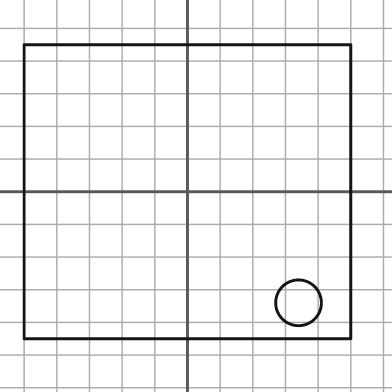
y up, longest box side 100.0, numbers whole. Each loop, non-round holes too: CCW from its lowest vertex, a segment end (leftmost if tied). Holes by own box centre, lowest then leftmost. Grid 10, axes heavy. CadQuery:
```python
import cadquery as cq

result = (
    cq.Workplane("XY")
    .moveTo(-50.0, -45.0)
    .lineTo(50.0, -45.0)
    .lineTo(50.0, 45.0)
    .lineTo(-50.0, 45.0)
    .close()
    .moveTo(34.0, -34.0)
    .circle(7.0)
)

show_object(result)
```